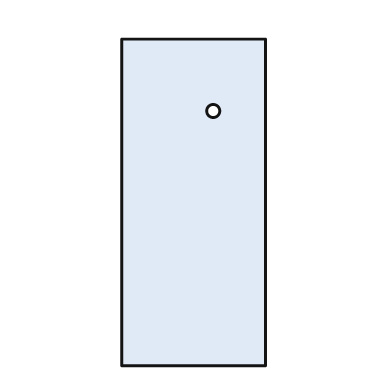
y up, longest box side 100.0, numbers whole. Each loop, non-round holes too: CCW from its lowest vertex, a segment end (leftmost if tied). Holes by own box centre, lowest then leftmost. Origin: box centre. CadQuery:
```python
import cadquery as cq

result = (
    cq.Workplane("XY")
    .moveTo(-22.0, -50.0)
    .lineTo(22.0, -50.0)
    .lineTo(22.0, 50.0)
    .lineTo(-22.0, 50.0)
    .close()
    .moveTo(6.0, 28.0)
    .circle(2.0)
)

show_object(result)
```